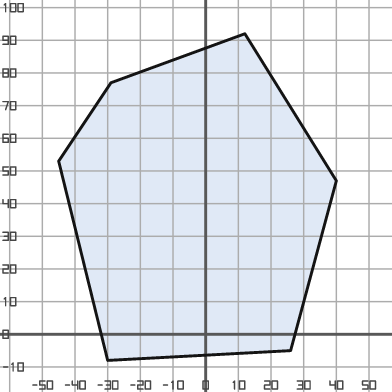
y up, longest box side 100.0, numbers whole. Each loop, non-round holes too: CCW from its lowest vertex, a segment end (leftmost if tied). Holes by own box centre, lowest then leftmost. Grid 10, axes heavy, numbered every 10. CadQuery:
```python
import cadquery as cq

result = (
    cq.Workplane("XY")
    .moveTo(-30.0, -8.0)
    .lineTo(26.0, -5.0)
    .lineTo(40.0, 47.0)
    .lineTo(12.0, 92.0)
    .lineTo(-29.0, 77.0)
    .lineTo(-45.0, 53.0)
    .close()
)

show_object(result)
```